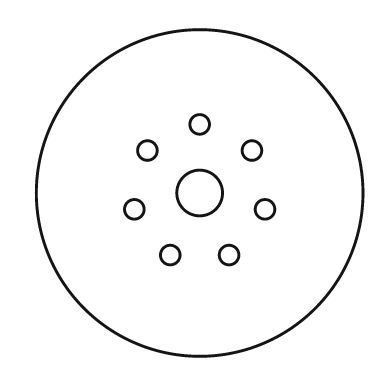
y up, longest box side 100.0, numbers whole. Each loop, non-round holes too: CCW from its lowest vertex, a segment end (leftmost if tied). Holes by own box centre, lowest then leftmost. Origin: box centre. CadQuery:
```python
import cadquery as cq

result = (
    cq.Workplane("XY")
    .moveTo(0.0, 0.0)
    .circle(50.0)
    .moveTo(-9.0, -19.0)
    .circle(3.0)
    .moveTo(9.0, -19.0)
    .circle(3.0)
    .moveTo(-20.0, -5.0)
    .circle(3.0)
    .moveTo(20.0, -5.0)
    .circle(3.0)
    .moveTo(0.0, 0.0)
    .circle(7.0)
    .moveTo(-16.0, 13.0)
    .circle(3.0)
    .moveTo(16.0, 13.0)
    .circle(3.0)
    .moveTo(0.0, 21.0)
    .circle(3.0)
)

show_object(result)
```